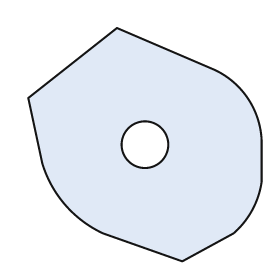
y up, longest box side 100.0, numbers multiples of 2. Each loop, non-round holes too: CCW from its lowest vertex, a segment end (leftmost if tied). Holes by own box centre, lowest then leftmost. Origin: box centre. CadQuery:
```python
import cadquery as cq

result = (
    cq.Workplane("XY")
    .moveTo(16.0, -50.0)
    .lineTo(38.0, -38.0)
    .threePointArc((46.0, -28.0), (50.0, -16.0))
    .lineTo(50.0, 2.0)
    .threePointArc((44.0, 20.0), (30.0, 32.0))
    .lineTo(-12.0, 50.0)
    .lineTo(-50.0, 20.0)
    .lineTo(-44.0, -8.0)
    .threePointArc((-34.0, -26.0), (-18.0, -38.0))
    .close()
    .moveTo(0.0, 0.0)
    .circle(10.0)
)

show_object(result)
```